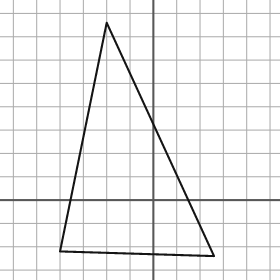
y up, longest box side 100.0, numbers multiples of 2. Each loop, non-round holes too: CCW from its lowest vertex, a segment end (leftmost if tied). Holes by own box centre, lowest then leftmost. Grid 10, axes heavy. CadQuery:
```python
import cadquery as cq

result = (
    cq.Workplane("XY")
    .moveTo(26.0, -24.0)
    .lineTo(-20.0, 76.0)
    .lineTo(-40.0, -22.0)
    .close()
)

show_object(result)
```